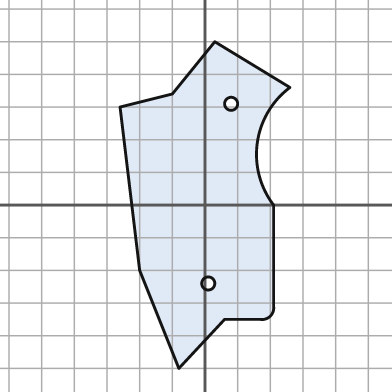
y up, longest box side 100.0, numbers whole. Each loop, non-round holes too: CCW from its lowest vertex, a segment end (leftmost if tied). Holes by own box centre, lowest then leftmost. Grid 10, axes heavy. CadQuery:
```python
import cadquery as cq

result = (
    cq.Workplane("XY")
    .moveTo(-8.0, -50.0)
    .lineTo(6.0, -35.0)
    .lineTo(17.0, -35.0)
    .threePointArc((20.0, -34.0), (21.0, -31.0))
    .lineTo(21.0, 0.0)
    .threePointArc((16.0, 19.0), (26.0, 36.0))
    .lineTo(3.0, 50.0)
    .lineTo(-10.0, 34.0)
    .lineTo(-26.0, 30.0)
    .lineTo(-20.0, -20.0)
    .close()
    .moveTo(1.0, -24.0)
    .circle(2.0)
    .moveTo(8.0, 31.0)
    .circle(2.0)
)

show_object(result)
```